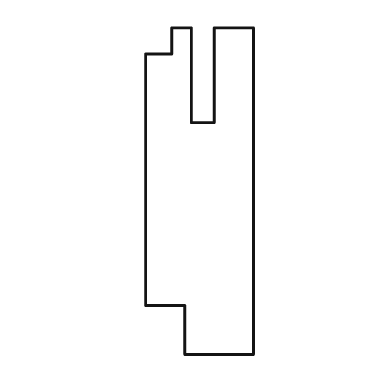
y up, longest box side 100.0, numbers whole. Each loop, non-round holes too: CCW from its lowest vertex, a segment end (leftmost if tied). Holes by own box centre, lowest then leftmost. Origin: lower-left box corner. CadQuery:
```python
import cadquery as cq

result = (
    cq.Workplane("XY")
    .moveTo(12.0, 0.0)
    .lineTo(33.0, 0.0)
    .lineTo(33.0, 100.0)
    .lineTo(21.0, 100.0)
    .lineTo(21.0, 71.0)
    .lineTo(14.0, 71.0)
    .lineTo(14.0, 100.0)
    .lineTo(8.0, 100.0)
    .lineTo(8.0, 92.0)
    .lineTo(0.0, 92.0)
    .lineTo(0.0, 15.0)
    .lineTo(12.0, 15.0)
    .close()
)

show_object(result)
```